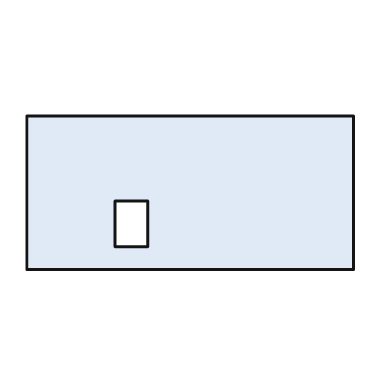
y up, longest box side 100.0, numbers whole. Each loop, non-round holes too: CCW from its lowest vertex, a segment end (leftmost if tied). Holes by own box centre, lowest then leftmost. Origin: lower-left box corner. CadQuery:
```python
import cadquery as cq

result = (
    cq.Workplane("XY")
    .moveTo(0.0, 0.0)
    .lineTo(100.0, 0.0)
    .lineTo(100.0, 47.0)
    .lineTo(0.0, 47.0)
    .close()
    .moveTo(27.0, 7.0)
    .lineTo(37.0, 7.0)
    .lineTo(37.0, 21.0)
    .lineTo(27.0, 21.0)
    .close()
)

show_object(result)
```